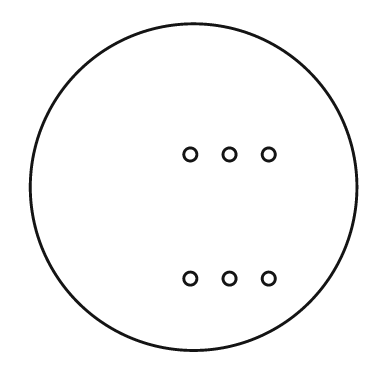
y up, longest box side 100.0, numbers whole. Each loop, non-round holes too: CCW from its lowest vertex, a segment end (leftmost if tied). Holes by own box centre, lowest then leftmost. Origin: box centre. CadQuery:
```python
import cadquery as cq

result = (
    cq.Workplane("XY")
    .moveTo(0.0, 0.0)
    .circle(50.0)
    .moveTo(-1.0, -28.0)
    .circle(2.0)
    .moveTo(11.0, -28.0)
    .circle(2.0)
    .moveTo(23.0, -28.0)
    .circle(2.0)
    .moveTo(-1.0, 10.0)
    .circle(2.0)
    .moveTo(11.0, 10.0)
    .circle(2.0)
    .moveTo(23.0, 10.0)
    .circle(2.0)
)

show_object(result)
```